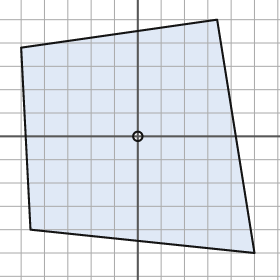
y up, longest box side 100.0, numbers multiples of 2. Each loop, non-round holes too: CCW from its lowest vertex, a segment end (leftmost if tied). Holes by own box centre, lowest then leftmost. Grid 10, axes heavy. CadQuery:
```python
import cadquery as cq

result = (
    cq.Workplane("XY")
    .moveTo(50.0, -50.0)
    .lineTo(34.0, 50.0)
    .lineTo(-50.0, 38.0)
    .lineTo(-46.0, -40.0)
    .close()
    .moveTo(0.0, 0.0)
    .circle(2.0)
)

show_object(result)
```